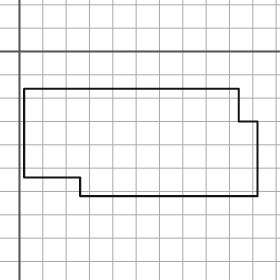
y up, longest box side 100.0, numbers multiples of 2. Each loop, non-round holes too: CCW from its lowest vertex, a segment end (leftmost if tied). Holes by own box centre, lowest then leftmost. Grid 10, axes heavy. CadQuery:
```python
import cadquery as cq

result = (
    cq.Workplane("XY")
    .moveTo(26.0, -62.0)
    .lineTo(102.0, -62.0)
    .lineTo(102.0, -30.0)
    .lineTo(94.0, -30.0)
    .lineTo(94.0, -16.0)
    .lineTo(2.0, -16.0)
    .lineTo(2.0, -54.0)
    .lineTo(26.0, -54.0)
    .close()
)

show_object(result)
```